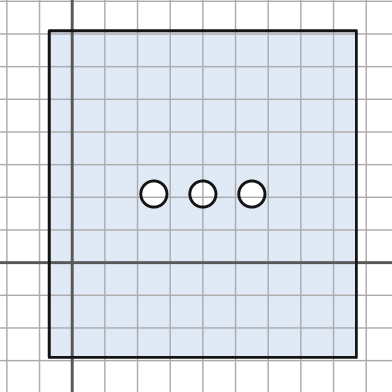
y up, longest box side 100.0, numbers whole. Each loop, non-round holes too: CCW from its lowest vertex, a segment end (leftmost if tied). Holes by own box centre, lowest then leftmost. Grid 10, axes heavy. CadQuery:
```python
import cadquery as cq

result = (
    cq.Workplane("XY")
    .moveTo(-7.0, -29.0)
    .lineTo(87.0, -29.0)
    .lineTo(87.0, 71.0)
    .lineTo(-7.0, 71.0)
    .close()
    .moveTo(25.0, 21.0)
    .circle(4.0)
    .moveTo(40.0, 21.0)
    .circle(4.0)
    .moveTo(55.0, 21.0)
    .circle(4.0)
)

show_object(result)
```